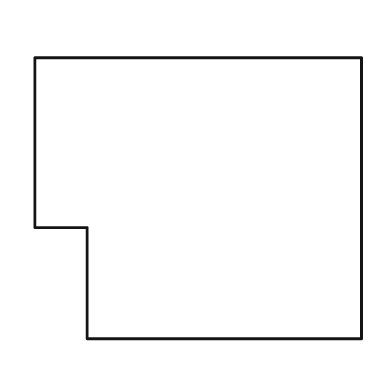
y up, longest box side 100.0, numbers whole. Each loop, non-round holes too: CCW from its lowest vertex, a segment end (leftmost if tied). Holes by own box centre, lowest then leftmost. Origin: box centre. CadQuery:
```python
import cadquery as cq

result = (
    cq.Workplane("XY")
    .moveTo(-34.0, -43.0)
    .lineTo(50.0, -43.0)
    .lineTo(50.0, 43.0)
    .lineTo(-50.0, 43.0)
    .lineTo(-50.0, -9.0)
    .lineTo(-34.0, -9.0)
    .close()
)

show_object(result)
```